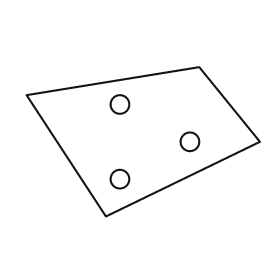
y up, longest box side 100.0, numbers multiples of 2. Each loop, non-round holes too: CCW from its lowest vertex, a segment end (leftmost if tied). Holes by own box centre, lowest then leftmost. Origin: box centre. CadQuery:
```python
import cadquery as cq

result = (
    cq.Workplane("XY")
    .moveTo(-16.0, -32.0)
    .lineTo(50.0, 0.0)
    .lineTo(24.0, 32.0)
    .lineTo(-50.0, 20.0)
    .close()
    .moveTo(-10.0, -16.0)
    .circle(4.0)
    .moveTo(20.0, 0.0)
    .circle(4.0)
    .moveTo(-10.0, 16.0)
    .circle(4.0)
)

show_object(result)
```